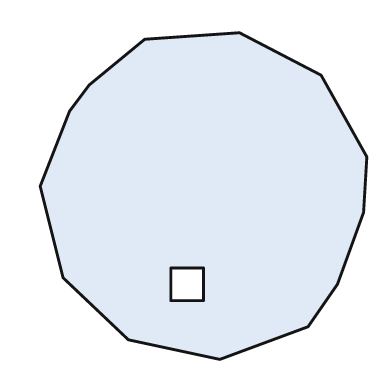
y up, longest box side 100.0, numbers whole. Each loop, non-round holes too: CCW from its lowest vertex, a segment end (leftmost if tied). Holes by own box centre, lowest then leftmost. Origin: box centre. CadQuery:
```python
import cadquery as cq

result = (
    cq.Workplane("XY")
    .moveTo(5.0, -50.0)
    .lineTo(32.0, -40.0)
    .lineTo(41.0, -27.0)
    .lineTo(49.0, -5.0)
    .lineTo(50.0, 12.0)
    .lineTo(36.0, 37.0)
    .lineTo(11.0, 50.0)
    .lineTo(-18.0, 48.0)
    .lineTo(-35.0, 34.0)
    .lineTo(-41.0, 26.0)
    .lineTo(-50.0, 3.0)
    .lineTo(-43.0, -25.0)
    .lineTo(-23.0, -44.0)
    .close()
    .moveTo(-10.0, -32.0)
    .lineTo(0.0, -32.0)
    .lineTo(0.0, -22.0)
    .lineTo(-10.0, -22.0)
    .close()
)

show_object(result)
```